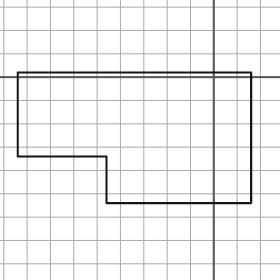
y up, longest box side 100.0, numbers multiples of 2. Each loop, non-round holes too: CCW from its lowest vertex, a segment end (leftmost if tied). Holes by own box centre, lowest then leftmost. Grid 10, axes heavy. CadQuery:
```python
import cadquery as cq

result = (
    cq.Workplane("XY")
    .moveTo(-46.0, -54.0)
    .lineTo(16.0, -54.0)
    .lineTo(16.0, 2.0)
    .lineTo(-84.0, 2.0)
    .lineTo(-84.0, -34.0)
    .lineTo(-46.0, -34.0)
    .close()
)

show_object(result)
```